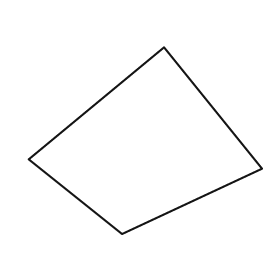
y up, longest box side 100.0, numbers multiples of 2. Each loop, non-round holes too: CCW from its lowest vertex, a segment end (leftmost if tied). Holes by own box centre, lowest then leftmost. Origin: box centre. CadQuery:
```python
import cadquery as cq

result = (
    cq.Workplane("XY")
    .moveTo(-10.0, -40.0)
    .lineTo(50.0, -12.0)
    .lineTo(8.0, 40.0)
    .lineTo(-50.0, -8.0)
    .close()
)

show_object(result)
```